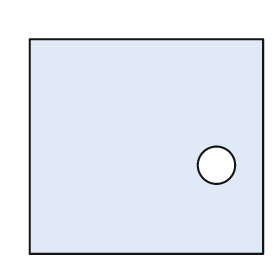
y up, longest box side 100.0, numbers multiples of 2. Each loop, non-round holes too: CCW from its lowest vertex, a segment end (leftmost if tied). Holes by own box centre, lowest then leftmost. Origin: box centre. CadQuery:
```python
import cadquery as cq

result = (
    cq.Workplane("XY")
    .moveTo(-50.0, -46.0)
    .lineTo(50.0, -46.0)
    .lineTo(50.0, 46.0)
    .lineTo(-50.0, 46.0)
    .close()
    .moveTo(30.0, -8.0)
    .circle(8.0)
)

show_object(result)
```